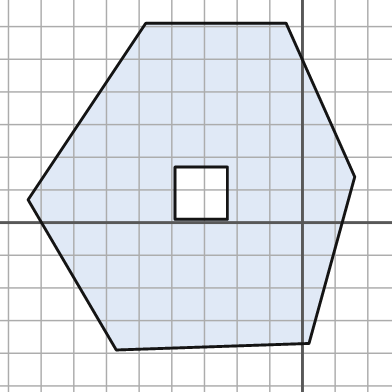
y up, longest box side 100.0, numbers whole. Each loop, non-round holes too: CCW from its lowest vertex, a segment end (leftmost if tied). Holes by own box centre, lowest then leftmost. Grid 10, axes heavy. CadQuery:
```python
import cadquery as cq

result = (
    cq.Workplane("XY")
    .moveTo(-57.0, -39.0)
    .lineTo(2.0, -37.0)
    .lineTo(16.0, 14.0)
    .lineTo(-5.0, 61.0)
    .lineTo(-48.0, 61.0)
    .lineTo(-84.0, 7.0)
    .close()
    .moveTo(-39.0, 1.0)
    .lineTo(-23.0, 1.0)
    .lineTo(-23.0, 17.0)
    .lineTo(-39.0, 17.0)
    .close()
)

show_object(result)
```